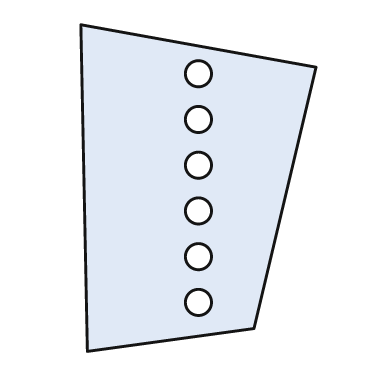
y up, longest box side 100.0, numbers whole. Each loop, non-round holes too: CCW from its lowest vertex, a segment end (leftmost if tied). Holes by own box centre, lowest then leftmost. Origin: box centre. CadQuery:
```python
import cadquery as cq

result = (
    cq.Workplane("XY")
    .moveTo(-34.0, -50.0)
    .lineTo(17.0, -43.0)
    .lineTo(36.0, 37.0)
    .lineTo(-36.0, 50.0)
    .close()
    .moveTo(0.0, -35.0)
    .circle(4.0)
    .moveTo(0.0, -21.0)
    .circle(4.0)
    .moveTo(0.0, -7.0)
    .circle(4.0)
    .moveTo(0.0, 7.0)
    .circle(4.0)
    .moveTo(0.0, 21.0)
    .circle(4.0)
    .moveTo(0.0, 35.0)
    .circle(4.0)
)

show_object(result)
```